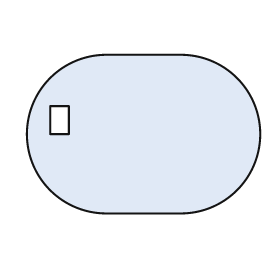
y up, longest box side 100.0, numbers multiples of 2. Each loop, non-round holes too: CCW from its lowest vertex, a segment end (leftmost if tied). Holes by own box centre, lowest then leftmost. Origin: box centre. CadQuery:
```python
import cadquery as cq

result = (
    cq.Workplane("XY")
    .moveTo(-16.0, -34.0)
    .lineTo(16.0, -34.0)
    .threePointArc((50.0, 0.0), (16.0, 34.0))
    .lineTo(-16.0, 34.0)
    .threePointArc((-50.0, 0.0), (-16.0, -34.0))
    .close()
    .moveTo(-40.0, 0.0)
    .lineTo(-32.0, 0.0)
    .lineTo(-32.0, 12.0)
    .lineTo(-40.0, 12.0)
    .close()
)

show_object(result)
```